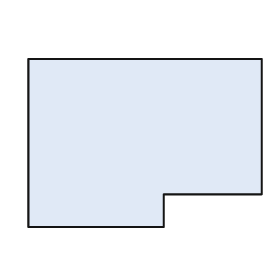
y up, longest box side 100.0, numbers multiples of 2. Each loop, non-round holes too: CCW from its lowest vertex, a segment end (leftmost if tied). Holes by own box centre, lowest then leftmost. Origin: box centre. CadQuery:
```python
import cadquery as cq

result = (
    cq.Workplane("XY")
    .moveTo(-50.0, -36.0)
    .lineTo(8.0, -36.0)
    .lineTo(8.0, -22.0)
    .lineTo(50.0, -22.0)
    .lineTo(50.0, 36.0)
    .lineTo(-50.0, 36.0)
    .close()
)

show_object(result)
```